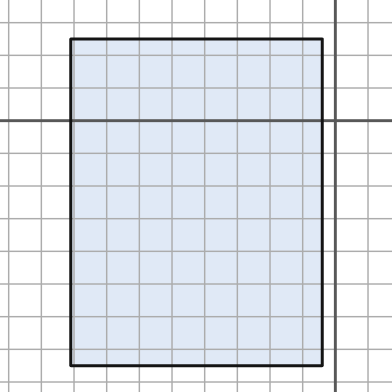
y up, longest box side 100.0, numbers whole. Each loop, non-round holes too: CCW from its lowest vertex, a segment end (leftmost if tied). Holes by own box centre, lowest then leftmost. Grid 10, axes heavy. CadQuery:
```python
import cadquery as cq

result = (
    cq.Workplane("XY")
    .moveTo(-81.0, -75.0)
    .lineTo(-4.0, -75.0)
    .lineTo(-4.0, 25.0)
    .lineTo(-81.0, 25.0)
    .close()
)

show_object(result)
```